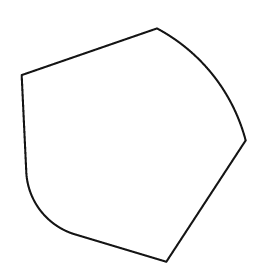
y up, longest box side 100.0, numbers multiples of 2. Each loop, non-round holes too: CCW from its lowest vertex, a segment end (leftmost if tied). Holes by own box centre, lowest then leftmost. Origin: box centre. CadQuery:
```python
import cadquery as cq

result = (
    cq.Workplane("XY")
    .moveTo(14.0, -50.0)
    .lineTo(48.0, 2.0)
    .threePointArc((34.0, 30.0), (10.0, 50.0))
    .lineTo(-48.0, 30.0)
    .lineTo(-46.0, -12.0)
    .threePointArc((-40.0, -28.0), (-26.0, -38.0))
    .close()
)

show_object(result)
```